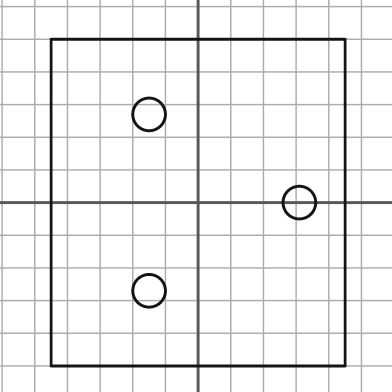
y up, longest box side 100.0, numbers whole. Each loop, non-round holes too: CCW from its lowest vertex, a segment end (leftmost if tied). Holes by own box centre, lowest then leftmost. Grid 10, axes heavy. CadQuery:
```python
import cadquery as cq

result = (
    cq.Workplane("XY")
    .moveTo(-45.0, -50.0)
    .lineTo(45.0, -50.0)
    .lineTo(45.0, 50.0)
    .lineTo(-45.0, 50.0)
    .close()
    .moveTo(-15.0, -27.0)
    .circle(5.0)
    .moveTo(31.0, 0.0)
    .circle(5.0)
    .moveTo(-15.0, 27.0)
    .circle(5.0)
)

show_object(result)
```